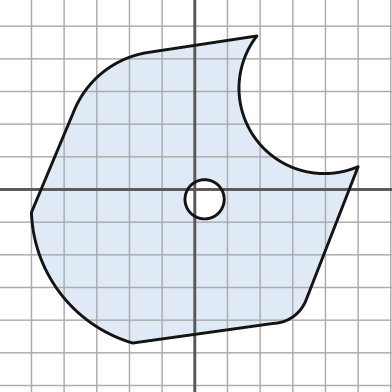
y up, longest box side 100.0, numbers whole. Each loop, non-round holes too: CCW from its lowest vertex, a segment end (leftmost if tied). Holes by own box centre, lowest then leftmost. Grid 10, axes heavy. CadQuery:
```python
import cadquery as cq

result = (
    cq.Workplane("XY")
    .moveTo(-19.0, -47.0)
    .lineTo(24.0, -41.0)
    .threePointArc((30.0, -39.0), (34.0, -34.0))
    .lineTo(50.0, 7.0)
    .threePointArc((19.0, 15.0), (19.0, 47.0))
    .lineTo(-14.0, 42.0)
    .threePointArc((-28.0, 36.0), (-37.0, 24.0))
    .lineTo(-50.0, -7.0)
    .threePointArc((-41.0, -32.0), (-19.0, -47.0))
    .close()
    .moveTo(3.0, -3.0)
    .circle(6.0)
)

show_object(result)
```